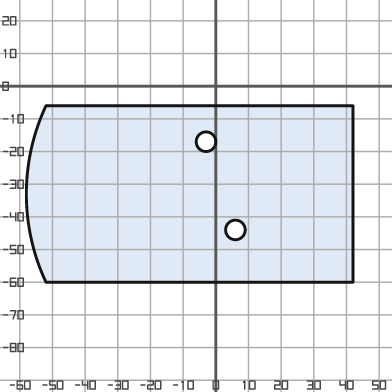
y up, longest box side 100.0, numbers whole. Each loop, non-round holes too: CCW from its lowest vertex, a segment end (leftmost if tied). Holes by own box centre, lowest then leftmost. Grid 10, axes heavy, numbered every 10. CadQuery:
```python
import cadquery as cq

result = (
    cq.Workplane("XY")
    .moveTo(-52.0, -60.0)
    .lineTo(42.0, -60.0)
    .lineTo(42.0, -6.0)
    .lineTo(-52.0, -6.0)
    .threePointArc((-58.0, -33.0), (-52.0, -60.0))
    .close()
    .moveTo(6.0, -44.0)
    .circle(3.0)
    .moveTo(-3.0, -17.0)
    .circle(3.0)
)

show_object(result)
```